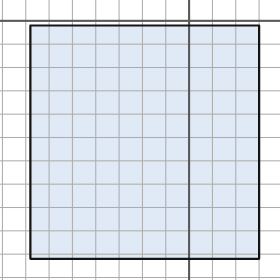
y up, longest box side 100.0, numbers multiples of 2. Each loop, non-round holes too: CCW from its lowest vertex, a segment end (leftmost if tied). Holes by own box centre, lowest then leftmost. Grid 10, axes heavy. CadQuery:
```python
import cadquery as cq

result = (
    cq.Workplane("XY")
    .moveTo(-68.0, -102.0)
    .lineTo(30.0, -102.0)
    .lineTo(30.0, -2.0)
    .lineTo(-68.0, -2.0)
    .close()
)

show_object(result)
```